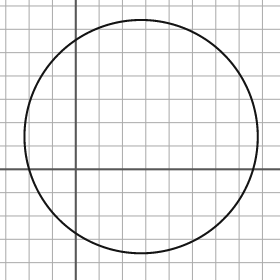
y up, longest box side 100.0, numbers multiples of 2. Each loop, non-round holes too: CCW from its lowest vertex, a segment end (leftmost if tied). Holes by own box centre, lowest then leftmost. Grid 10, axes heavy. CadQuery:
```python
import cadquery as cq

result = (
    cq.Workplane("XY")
    .moveTo(28.0, 14.0)
    .circle(50.0)
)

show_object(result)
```